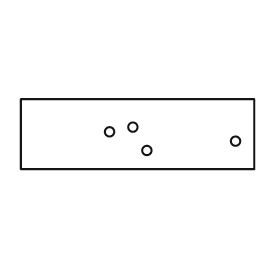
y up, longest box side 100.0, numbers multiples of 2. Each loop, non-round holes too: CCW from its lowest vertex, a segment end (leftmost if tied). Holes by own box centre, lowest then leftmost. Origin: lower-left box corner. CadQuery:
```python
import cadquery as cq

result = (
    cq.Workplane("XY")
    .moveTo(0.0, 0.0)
    .lineTo(100.0, 0.0)
    .lineTo(100.0, 30.0)
    .lineTo(0.0, 30.0)
    .close()
    .moveTo(54.0, 8.0)
    .circle(2.0)
    .moveTo(92.0, 12.0)
    .circle(2.0)
    .moveTo(38.0, 16.0)
    .circle(2.0)
    .moveTo(48.0, 18.0)
    .circle(2.0)
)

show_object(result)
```